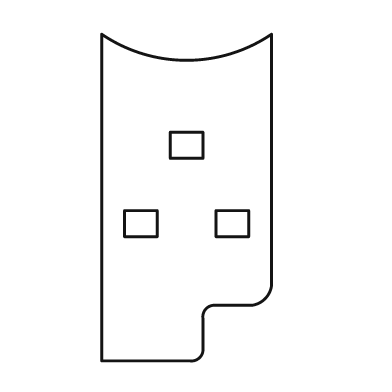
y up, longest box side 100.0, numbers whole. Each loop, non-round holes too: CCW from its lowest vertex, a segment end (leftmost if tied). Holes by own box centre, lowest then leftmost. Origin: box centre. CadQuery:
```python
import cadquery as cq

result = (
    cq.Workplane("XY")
    .moveTo(-26.0, -50.0)
    .lineTo(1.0, -50.0)
    .threePointArc((4.0, -49.0), (5.0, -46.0))
    .lineTo(5.0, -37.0)
    .threePointArc((6.0, -34.0), (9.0, -33.0))
    .lineTo(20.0, -33.0)
    .threePointArc((24.0, -31.0), (26.0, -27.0))
    .lineTo(26.0, 50.0)
    .threePointArc((0.0, 42.0), (-26.0, 50.0))
    .close()
    .moveTo(-19.0, -12.0)
    .lineTo(-9.0, -12.0)
    .lineTo(-9.0, -4.0)
    .lineTo(-19.0, -4.0)
    .close()
    .moveTo(9.0, -12.0)
    .lineTo(19.0, -12.0)
    .lineTo(19.0, -4.0)
    .lineTo(9.0, -4.0)
    .close()
    .moveTo(-5.0, 12.0)
    .lineTo(5.0, 12.0)
    .lineTo(5.0, 20.0)
    .lineTo(-5.0, 20.0)
    .close()
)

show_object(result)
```